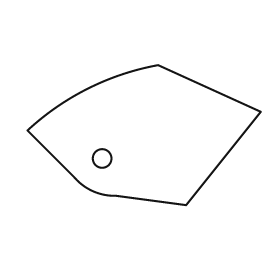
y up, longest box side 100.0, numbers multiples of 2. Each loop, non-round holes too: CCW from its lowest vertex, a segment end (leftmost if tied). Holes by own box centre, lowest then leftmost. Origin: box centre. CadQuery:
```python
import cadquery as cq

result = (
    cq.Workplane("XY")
    .moveTo(18.0, -30.0)
    .lineTo(50.0, 10.0)
    .lineTo(6.0, 30.0)
    .threePointArc((-24.0, 20.0), (-50.0, 2.0))
    .lineTo(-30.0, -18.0)
    .threePointArc((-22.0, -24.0), (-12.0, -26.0))
    .close()
    .moveTo(-18.0, -10.0)
    .circle(4.0)
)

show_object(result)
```